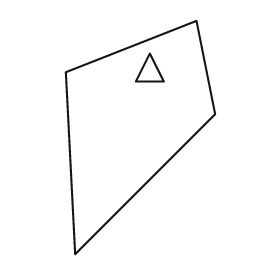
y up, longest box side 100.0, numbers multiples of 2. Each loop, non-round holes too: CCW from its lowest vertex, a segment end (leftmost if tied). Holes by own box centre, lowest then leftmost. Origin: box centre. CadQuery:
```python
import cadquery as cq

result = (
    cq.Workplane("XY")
    .moveTo(-28.0, -50.0)
    .lineTo(32.0, 10.0)
    .lineTo(24.0, 50.0)
    .lineTo(-32.0, 28.0)
    .close()
    .moveTo(-2.0, 24.0)
    .lineTo(10.0, 24.0)
    .lineTo(4.0, 36.0)
    .close()
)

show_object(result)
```